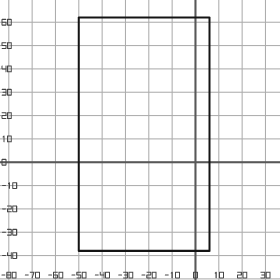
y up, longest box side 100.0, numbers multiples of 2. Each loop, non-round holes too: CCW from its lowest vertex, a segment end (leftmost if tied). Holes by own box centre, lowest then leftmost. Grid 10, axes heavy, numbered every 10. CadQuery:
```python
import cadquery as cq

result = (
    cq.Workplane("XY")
    .moveTo(-50.0, -38.0)
    .lineTo(6.0, -38.0)
    .lineTo(6.0, 62.0)
    .lineTo(-50.0, 62.0)
    .close()
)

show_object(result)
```